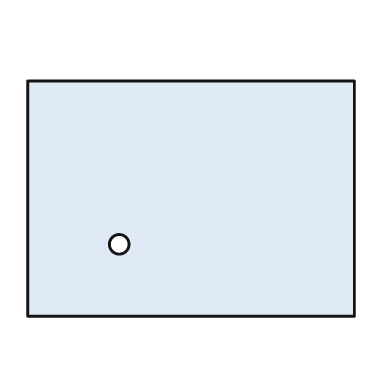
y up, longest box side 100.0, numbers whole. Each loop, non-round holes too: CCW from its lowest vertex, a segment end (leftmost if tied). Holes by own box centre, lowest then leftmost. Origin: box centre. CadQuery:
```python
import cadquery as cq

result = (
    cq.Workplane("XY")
    .moveTo(-50.0, -36.0)
    .lineTo(50.0, -36.0)
    .lineTo(50.0, 36.0)
    .lineTo(-50.0, 36.0)
    .close()
    .moveTo(-22.0, -14.0)
    .circle(3.0)
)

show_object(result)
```